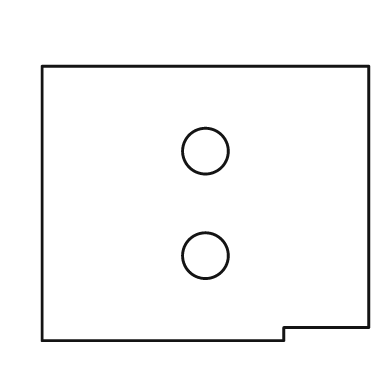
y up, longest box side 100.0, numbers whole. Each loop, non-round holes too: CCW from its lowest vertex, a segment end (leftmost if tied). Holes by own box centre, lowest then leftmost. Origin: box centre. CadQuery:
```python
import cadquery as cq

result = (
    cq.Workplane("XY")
    .moveTo(-50.0, -42.0)
    .lineTo(24.0, -42.0)
    .lineTo(24.0, -38.0)
    .lineTo(50.0, -38.0)
    .lineTo(50.0, 42.0)
    .lineTo(-50.0, 42.0)
    .close()
    .moveTo(0.0, -16.0)
    .circle(7.0)
    .moveTo(0.0, 16.0)
    .circle(7.0)
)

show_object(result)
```